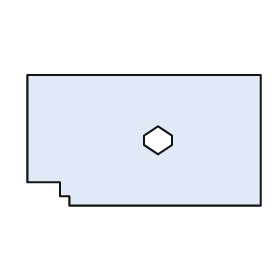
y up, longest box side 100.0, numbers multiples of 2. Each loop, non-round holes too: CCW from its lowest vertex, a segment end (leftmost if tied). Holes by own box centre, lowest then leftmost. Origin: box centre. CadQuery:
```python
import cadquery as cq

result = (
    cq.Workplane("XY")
    .moveTo(-32.0, -28.0)
    .lineTo(50.0, -28.0)
    .lineTo(50.0, 28.0)
    .lineTo(-50.0, 28.0)
    .lineTo(-50.0, -18.0)
    .lineTo(-36.0, -18.0)
    .lineTo(-36.0, -24.0)
    .lineTo(-32.0, -24.0)
    .close()
    .moveTo(6.0, -6.0)
    .lineTo(12.0, -2.0)
    .lineTo(12.0, 2.0)
    .lineTo(6.0, 6.0)
    .lineTo(0.0, 2.0)
    .lineTo(0.0, -2.0)
    .close()
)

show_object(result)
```